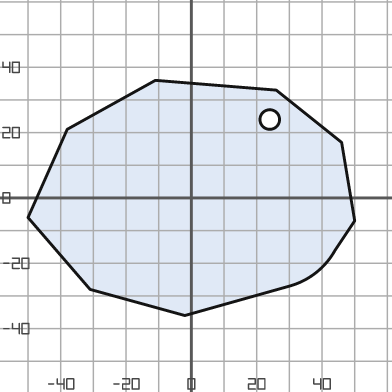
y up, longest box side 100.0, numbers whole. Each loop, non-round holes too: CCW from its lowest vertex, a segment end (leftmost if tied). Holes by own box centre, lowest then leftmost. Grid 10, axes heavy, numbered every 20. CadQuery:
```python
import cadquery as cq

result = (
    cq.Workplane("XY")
    .moveTo(-2.0, -36.0)
    .lineTo(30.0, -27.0)
    .threePointArc((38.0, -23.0), (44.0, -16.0))
    .lineTo(50.0, -7.0)
    .lineTo(46.0, 17.0)
    .lineTo(26.0, 33.0)
    .lineTo(-11.0, 36.0)
    .lineTo(-38.0, 21.0)
    .lineTo(-50.0, -6.0)
    .lineTo(-31.0, -28.0)
    .close()
    .moveTo(24.0, 24.0)
    .circle(3.0)
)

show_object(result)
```